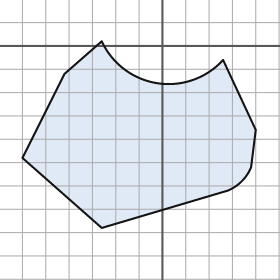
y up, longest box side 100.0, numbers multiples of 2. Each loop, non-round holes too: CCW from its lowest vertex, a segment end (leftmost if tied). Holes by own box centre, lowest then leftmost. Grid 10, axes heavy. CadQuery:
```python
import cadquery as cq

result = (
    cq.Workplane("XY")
    .moveTo(-26.0, -78.0)
    .lineTo(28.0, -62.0)
    .threePointArc((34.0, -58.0), (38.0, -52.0))
    .lineTo(40.0, -36.0)
    .lineTo(26.0, -6.0)
    .threePointArc((-2.0, -16.0), (-26.0, 2.0))
    .lineTo(-42.0, -12.0)
    .lineTo(-60.0, -48.0)
    .close()
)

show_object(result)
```